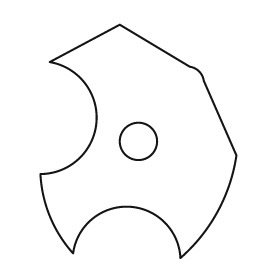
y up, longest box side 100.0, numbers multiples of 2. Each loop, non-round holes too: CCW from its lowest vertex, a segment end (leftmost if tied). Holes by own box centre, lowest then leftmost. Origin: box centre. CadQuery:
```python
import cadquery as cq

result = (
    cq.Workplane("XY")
    .moveTo(18.0, -50.0)
    .threePointArc((34.0, -30.0), (42.0, -6.0))
    .lineTo(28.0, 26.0)
    .threePointArc((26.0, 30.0), (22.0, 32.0))
    .lineTo(-8.0, 50.0)
    .lineTo(-38.0, 34.0)
    .threePointArc((-18.0, 8.0), (-42.0, -14.0))
    .threePointArc((-38.0, -32.0), (-28.0, -48.0))
    .threePointArc((-4.0, -28.0), (18.0, -50.0))
    .close()
    .moveTo(0.0, 0.0)
    .circle(8.0)
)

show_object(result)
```